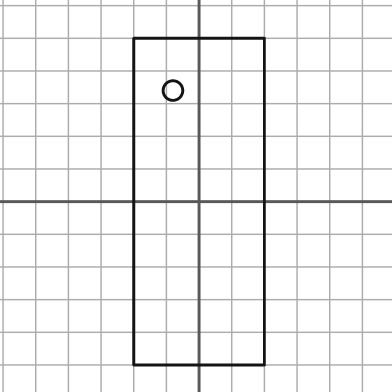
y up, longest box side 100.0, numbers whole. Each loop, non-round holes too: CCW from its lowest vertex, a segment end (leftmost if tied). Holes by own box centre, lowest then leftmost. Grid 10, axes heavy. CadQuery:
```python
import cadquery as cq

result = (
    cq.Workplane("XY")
    .moveTo(-20.0, -50.0)
    .lineTo(20.0, -50.0)
    .lineTo(20.0, 50.0)
    .lineTo(-20.0, 50.0)
    .close()
    .moveTo(-8.0, 34.0)
    .circle(3.0)
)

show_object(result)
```